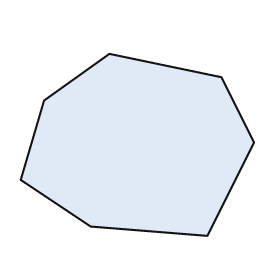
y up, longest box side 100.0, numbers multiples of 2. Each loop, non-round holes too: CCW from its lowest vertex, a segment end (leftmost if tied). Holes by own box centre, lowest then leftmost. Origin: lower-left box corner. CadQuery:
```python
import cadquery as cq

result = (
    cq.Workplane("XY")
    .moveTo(80.0, 0.0)
    .lineTo(100.0, 40.0)
    .lineTo(86.0, 68.0)
    .lineTo(38.0, 78.0)
    .lineTo(10.0, 58.0)
    .lineTo(0.0, 24.0)
    .lineTo(30.0, 4.0)
    .close()
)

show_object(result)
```